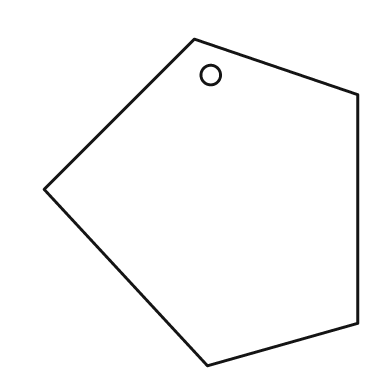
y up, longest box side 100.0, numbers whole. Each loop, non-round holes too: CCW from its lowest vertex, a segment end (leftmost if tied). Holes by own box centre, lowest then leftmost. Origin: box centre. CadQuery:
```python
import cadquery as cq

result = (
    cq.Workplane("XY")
    .moveTo(2.0, -50.0)
    .lineTo(48.0, -37.0)
    .lineTo(48.0, 33.0)
    .lineTo(-2.0, 50.0)
    .lineTo(-48.0, 4.0)
    .close()
    .moveTo(3.0, 39.0)
    .circle(3.0)
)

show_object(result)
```